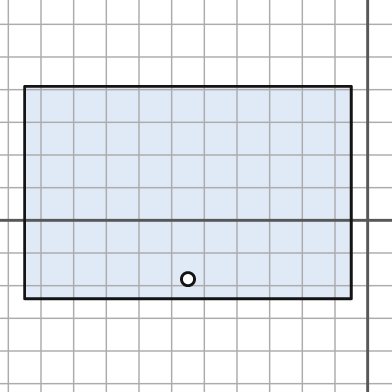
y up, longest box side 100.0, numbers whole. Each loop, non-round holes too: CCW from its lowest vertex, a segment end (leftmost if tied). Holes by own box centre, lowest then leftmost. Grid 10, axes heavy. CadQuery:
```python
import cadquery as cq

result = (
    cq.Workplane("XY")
    .moveTo(-105.0, -24.0)
    .lineTo(-5.0, -24.0)
    .lineTo(-5.0, 41.0)
    .lineTo(-105.0, 41.0)
    .close()
    .moveTo(-55.0, -18.0)
    .circle(2.0)
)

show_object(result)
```